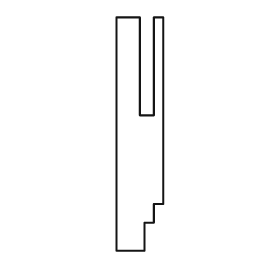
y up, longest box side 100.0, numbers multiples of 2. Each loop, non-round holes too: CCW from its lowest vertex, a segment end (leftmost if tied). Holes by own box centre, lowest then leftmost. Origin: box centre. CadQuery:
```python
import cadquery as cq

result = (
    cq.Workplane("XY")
    .moveTo(-10.0, -50.0)
    .lineTo(2.0, -50.0)
    .lineTo(2.0, -38.0)
    .lineTo(6.0, -38.0)
    .lineTo(6.0, -30.0)
    .lineTo(10.0, -30.0)
    .lineTo(10.0, 50.0)
    .lineTo(6.0, 50.0)
    .lineTo(6.0, 8.0)
    .lineTo(0.0, 8.0)
    .lineTo(0.0, 50.0)
    .lineTo(-10.0, 50.0)
    .close()
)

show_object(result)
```